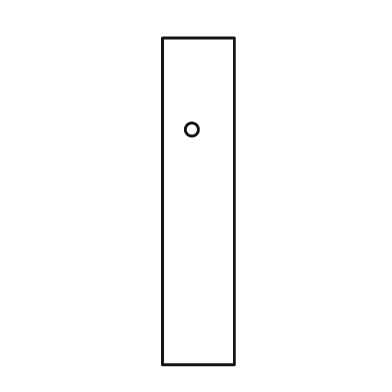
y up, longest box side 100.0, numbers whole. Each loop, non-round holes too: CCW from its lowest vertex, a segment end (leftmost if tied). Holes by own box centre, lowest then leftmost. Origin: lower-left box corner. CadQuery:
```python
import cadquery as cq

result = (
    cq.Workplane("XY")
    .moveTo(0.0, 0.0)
    .lineTo(22.0, 0.0)
    .lineTo(22.0, 100.0)
    .lineTo(0.0, 100.0)
    .close()
    .moveTo(9.0, 72.0)
    .circle(2.0)
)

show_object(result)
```